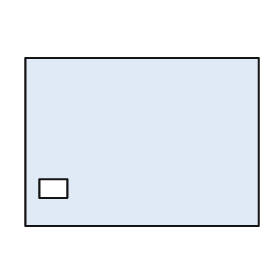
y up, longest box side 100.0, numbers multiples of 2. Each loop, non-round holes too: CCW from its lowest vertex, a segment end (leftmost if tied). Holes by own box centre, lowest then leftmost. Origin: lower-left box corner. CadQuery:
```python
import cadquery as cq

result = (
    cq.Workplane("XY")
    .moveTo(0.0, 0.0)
    .lineTo(100.0, 0.0)
    .lineTo(100.0, 72.0)
    .lineTo(0.0, 72.0)
    .close()
    .moveTo(6.0, 12.0)
    .lineTo(18.0, 12.0)
    .lineTo(18.0, 20.0)
    .lineTo(6.0, 20.0)
    .close()
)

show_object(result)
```